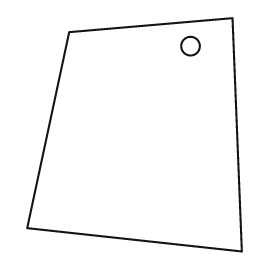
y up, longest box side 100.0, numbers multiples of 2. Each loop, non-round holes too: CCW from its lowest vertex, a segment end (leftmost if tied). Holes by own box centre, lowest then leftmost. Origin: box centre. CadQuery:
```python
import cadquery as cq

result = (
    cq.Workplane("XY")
    .moveTo(46.0, -50.0)
    .lineTo(42.0, 50.0)
    .lineTo(-28.0, 44.0)
    .lineTo(-46.0, -40.0)
    .close()
    .moveTo(24.0, 38.0)
    .circle(4.0)
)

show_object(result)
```